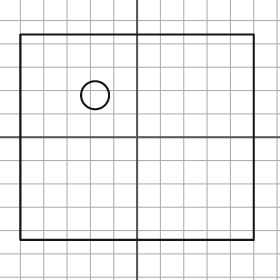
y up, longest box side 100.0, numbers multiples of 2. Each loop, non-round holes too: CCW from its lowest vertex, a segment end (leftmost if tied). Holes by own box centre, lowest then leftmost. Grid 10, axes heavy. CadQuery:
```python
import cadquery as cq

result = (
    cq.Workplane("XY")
    .moveTo(-50.0, -44.0)
    .lineTo(50.0, -44.0)
    .lineTo(50.0, 44.0)
    .lineTo(-50.0, 44.0)
    .close()
    .moveTo(-18.0, 18.0)
    .circle(6.0)
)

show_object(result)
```